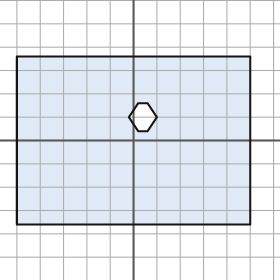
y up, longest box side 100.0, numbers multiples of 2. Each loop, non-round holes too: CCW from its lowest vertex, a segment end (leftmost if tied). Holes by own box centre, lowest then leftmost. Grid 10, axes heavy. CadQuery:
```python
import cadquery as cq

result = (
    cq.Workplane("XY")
    .moveTo(-50.0, -36.0)
    .lineTo(50.0, -36.0)
    .lineTo(50.0, 36.0)
    .lineTo(-50.0, 36.0)
    .close()
    .moveTo(2.0, 4.0)
    .lineTo(6.0, 4.0)
    .lineTo(10.0, 10.0)
    .lineTo(6.0, 16.0)
    .lineTo(2.0, 16.0)
    .lineTo(-2.0, 10.0)
    .close()
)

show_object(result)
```